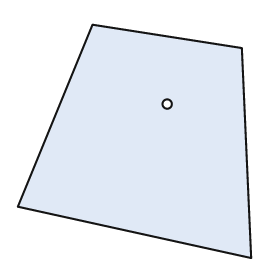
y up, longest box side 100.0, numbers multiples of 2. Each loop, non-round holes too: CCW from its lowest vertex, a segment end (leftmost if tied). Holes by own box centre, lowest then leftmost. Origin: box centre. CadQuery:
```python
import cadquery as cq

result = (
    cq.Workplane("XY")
    .moveTo(50.0, -50.0)
    .lineTo(46.0, 40.0)
    .lineTo(-18.0, 50.0)
    .lineTo(-50.0, -28.0)
    .close()
    .moveTo(14.0, 16.0)
    .circle(2.0)
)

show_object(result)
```